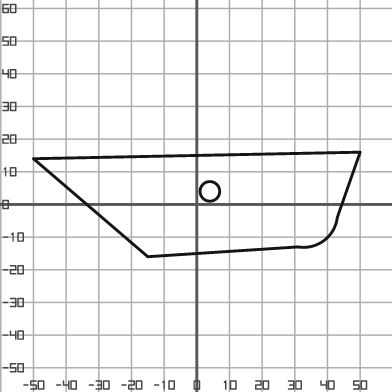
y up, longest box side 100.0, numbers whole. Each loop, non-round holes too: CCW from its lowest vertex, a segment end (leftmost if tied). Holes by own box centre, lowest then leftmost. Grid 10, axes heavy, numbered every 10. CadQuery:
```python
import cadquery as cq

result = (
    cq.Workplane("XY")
    .moveTo(-15.0, -16.0)
    .lineTo(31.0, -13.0)
    .threePointArc((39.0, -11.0), (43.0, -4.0))
    .lineTo(50.0, 16.0)
    .lineTo(-50.0, 14.0)
    .close()
    .moveTo(4.0, 4.0)
    .circle(3.0)
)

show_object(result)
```